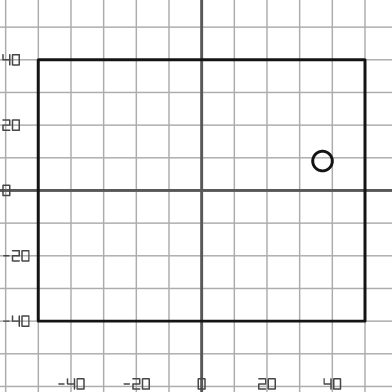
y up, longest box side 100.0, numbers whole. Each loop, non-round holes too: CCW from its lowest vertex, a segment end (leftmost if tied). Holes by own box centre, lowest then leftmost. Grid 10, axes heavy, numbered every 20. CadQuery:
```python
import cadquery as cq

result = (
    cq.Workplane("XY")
    .moveTo(-50.0, -40.0)
    .lineTo(50.0, -40.0)
    .lineTo(50.0, 40.0)
    .lineTo(-50.0, 40.0)
    .close()
    .moveTo(37.0, 9.0)
    .circle(3.0)
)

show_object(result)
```